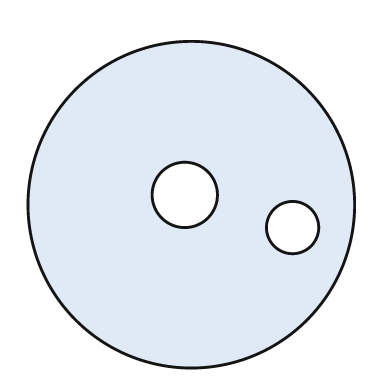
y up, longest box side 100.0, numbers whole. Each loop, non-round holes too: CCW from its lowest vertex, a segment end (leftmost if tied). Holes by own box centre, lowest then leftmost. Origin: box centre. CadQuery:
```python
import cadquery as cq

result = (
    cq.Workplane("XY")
    .moveTo(0.0, 0.0)
    .circle(50.0)
    .moveTo(31.0, -7.0)
    .circle(8.0)
    .moveTo(-2.0, 3.0)
    .circle(10.0)
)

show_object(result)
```